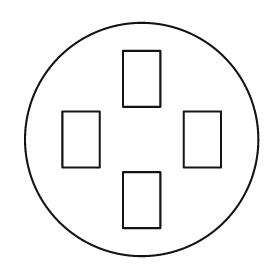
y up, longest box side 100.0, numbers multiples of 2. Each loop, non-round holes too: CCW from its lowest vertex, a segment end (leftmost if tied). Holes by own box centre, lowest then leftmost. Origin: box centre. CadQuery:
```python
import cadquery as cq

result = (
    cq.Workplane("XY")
    .moveTo(0.0, 0.0)
    .circle(50.0)
    .moveTo(-8.0, -38.0)
    .lineTo(8.0, -38.0)
    .lineTo(8.0, -14.0)
    .lineTo(-8.0, -14.0)
    .close()
    .moveTo(-34.0, -12.0)
    .lineTo(-18.0, -12.0)
    .lineTo(-18.0, 12.0)
    .lineTo(-34.0, 12.0)
    .close()
    .moveTo(18.0, -12.0)
    .lineTo(34.0, -12.0)
    .lineTo(34.0, 12.0)
    .lineTo(18.0, 12.0)
    .close()
    .moveTo(-8.0, 14.0)
    .lineTo(8.0, 14.0)
    .lineTo(8.0, 38.0)
    .lineTo(-8.0, 38.0)
    .close()
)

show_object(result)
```